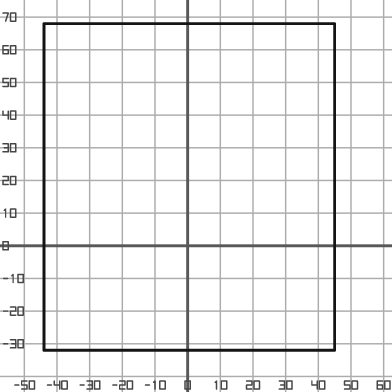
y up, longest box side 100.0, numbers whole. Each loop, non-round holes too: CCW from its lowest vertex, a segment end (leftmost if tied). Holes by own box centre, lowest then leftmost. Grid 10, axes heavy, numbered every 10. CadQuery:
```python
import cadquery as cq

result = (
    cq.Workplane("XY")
    .moveTo(-44.0, -32.0)
    .lineTo(45.0, -32.0)
    .lineTo(45.0, 68.0)
    .lineTo(-44.0, 68.0)
    .close()
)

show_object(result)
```